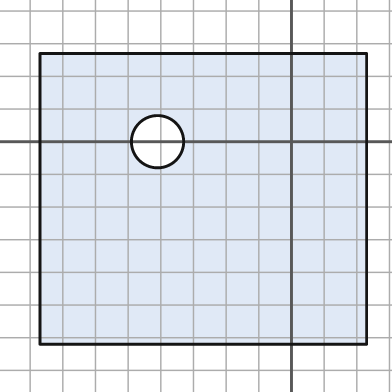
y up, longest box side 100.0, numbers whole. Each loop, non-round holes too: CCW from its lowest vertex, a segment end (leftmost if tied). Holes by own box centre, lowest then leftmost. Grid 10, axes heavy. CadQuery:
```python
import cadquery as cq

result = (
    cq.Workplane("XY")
    .moveTo(-77.0, -62.0)
    .lineTo(23.0, -62.0)
    .lineTo(23.0, 27.0)
    .lineTo(-77.0, 27.0)
    .close()
    .moveTo(-41.0, 0.0)
    .circle(8.0)
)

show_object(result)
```